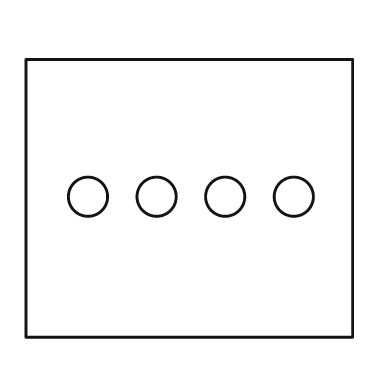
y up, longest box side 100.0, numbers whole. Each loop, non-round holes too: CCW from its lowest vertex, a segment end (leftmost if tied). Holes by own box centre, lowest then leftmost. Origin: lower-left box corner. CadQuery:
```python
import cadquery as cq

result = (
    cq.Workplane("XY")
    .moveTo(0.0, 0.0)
    .lineTo(100.0, 0.0)
    .lineTo(100.0, 85.0)
    .lineTo(0.0, 85.0)
    .close()
    .moveTo(19.0, 43.0)
    .circle(6.0)
    .moveTo(40.0, 43.0)
    .circle(6.0)
    .moveTo(61.0, 43.0)
    .circle(6.0)
    .moveTo(82.0, 43.0)
    .circle(6.0)
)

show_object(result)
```